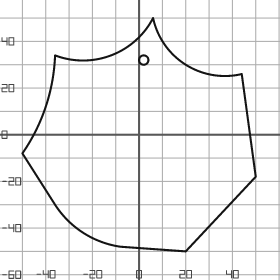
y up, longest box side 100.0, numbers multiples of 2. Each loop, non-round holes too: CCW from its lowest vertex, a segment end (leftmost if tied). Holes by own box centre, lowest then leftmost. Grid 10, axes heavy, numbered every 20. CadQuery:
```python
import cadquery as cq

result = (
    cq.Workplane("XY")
    .moveTo(20.0, -50.0)
    .lineTo(50.0, -18.0)
    .lineTo(44.0, 26.0)
    .threePointArc((20.0, 30.0), (6.0, 50.0))
    .threePointArc((-12.0, 34.0), (-36.0, 34.0))
    .threePointArc((-40.0, 12.0), (-50.0, -8.0))
    .lineTo(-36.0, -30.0)
    .threePointArc((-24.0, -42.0), (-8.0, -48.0))
    .close()
    .moveTo(2.0, 32.0)
    .circle(2.0)
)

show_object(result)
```